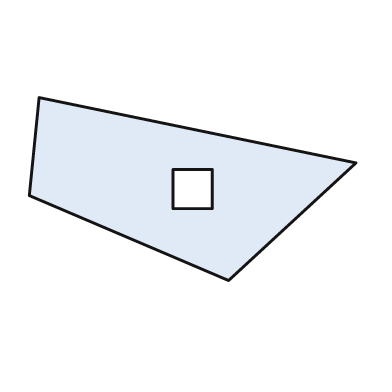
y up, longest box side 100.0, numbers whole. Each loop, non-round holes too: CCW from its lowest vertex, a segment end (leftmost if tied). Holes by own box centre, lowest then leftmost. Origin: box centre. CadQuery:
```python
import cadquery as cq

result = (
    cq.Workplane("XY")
    .moveTo(11.0, -28.0)
    .lineTo(50.0, 8.0)
    .lineTo(-47.0, 28.0)
    .lineTo(-50.0, -2.0)
    .close()
    .moveTo(-6.0, -6.0)
    .lineTo(6.0, -6.0)
    .lineTo(6.0, 6.0)
    .lineTo(-6.0, 6.0)
    .close()
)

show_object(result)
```